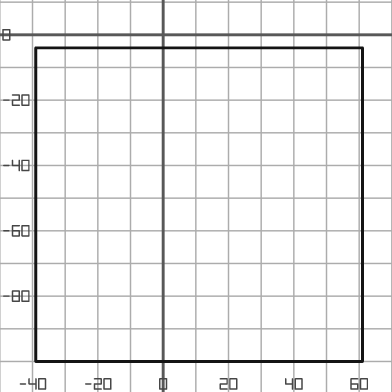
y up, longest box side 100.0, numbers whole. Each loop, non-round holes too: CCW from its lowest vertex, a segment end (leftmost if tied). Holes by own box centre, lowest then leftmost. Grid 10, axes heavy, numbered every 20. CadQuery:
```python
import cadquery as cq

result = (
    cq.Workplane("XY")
    .moveTo(-39.0, -100.0)
    .lineTo(61.0, -100.0)
    .lineTo(61.0, -4.0)
    .lineTo(-39.0, -4.0)
    .close()
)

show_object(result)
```